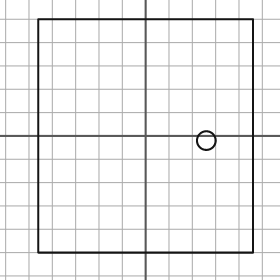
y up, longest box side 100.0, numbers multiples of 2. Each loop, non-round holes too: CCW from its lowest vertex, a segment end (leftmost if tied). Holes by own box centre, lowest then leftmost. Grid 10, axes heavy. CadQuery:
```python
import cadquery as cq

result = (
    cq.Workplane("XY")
    .moveTo(-46.0, -50.0)
    .lineTo(46.0, -50.0)
    .lineTo(46.0, 50.0)
    .lineTo(-46.0, 50.0)
    .close()
    .moveTo(26.0, -2.0)
    .circle(4.0)
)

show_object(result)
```